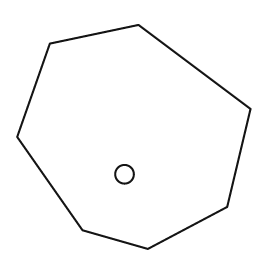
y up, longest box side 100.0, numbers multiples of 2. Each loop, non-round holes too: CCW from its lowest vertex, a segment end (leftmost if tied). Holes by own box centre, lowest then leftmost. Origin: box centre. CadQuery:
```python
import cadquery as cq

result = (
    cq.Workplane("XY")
    .moveTo(6.0, -48.0)
    .lineTo(40.0, -30.0)
    .lineTo(50.0, 12.0)
    .lineTo(2.0, 48.0)
    .lineTo(-36.0, 40.0)
    .lineTo(-50.0, 0.0)
    .lineTo(-22.0, -40.0)
    .close()
    .moveTo(-4.0, -16.0)
    .circle(4.0)
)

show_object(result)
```